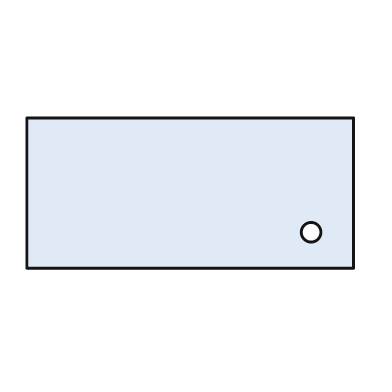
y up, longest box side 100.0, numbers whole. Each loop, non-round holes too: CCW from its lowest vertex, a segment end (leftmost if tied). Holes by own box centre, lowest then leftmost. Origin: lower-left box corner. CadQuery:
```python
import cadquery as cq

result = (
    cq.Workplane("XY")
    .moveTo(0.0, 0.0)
    .lineTo(100.0, 0.0)
    .lineTo(100.0, 46.0)
    .lineTo(0.0, 46.0)
    .close()
    .moveTo(87.0, 11.0)
    .circle(3.0)
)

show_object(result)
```